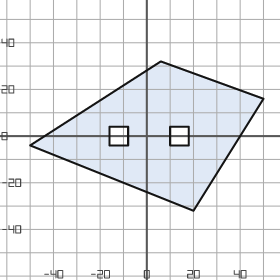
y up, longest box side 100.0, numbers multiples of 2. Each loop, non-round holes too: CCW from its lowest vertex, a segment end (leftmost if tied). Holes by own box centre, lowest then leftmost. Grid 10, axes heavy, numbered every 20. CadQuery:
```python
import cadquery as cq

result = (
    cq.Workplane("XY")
    .moveTo(20.0, -32.0)
    .lineTo(50.0, 16.0)
    .lineTo(6.0, 32.0)
    .lineTo(-50.0, -4.0)
    .close()
    .moveTo(-16.0, -4.0)
    .lineTo(-8.0, -4.0)
    .lineTo(-8.0, 4.0)
    .lineTo(-16.0, 4.0)
    .close()
    .moveTo(10.0, -4.0)
    .lineTo(18.0, -4.0)
    .lineTo(18.0, 4.0)
    .lineTo(10.0, 4.0)
    .close()
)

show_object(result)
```